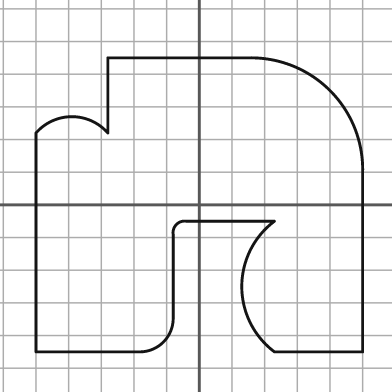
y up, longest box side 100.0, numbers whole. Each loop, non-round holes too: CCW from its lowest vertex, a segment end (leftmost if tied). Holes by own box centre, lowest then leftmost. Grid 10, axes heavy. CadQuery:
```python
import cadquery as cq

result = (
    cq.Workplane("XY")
    .moveTo(-50.0, -45.0)
    .lineTo(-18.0, -45.0)
    .threePointArc((-11.0, -42.0), (-8.0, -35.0))
    .lineTo(-8.0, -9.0)
    .threePointArc((-7.0, -6.0), (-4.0, -5.0))
    .lineTo(23.0, -5.0)
    .threePointArc((13.0, -25.0), (23.0, -45.0))
    .lineTo(50.0, -45.0)
    .lineTo(50.0, 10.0)
    .threePointArc((40.0, 35.0), (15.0, 45.0))
    .lineTo(-28.0, 45.0)
    .lineTo(-28.0, 22.0)
    .threePointArc((-39.0, 27.0), (-50.0, 22.0))
    .close()
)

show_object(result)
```